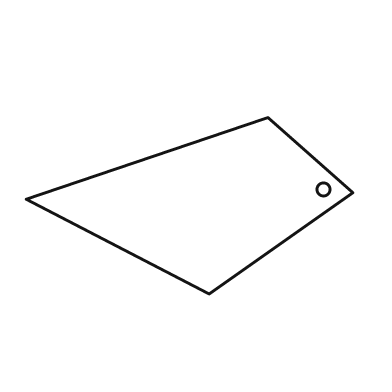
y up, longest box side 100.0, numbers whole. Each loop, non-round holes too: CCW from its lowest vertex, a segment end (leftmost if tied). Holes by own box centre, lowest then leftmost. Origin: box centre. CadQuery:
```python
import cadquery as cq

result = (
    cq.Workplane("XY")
    .moveTo(6.0, -27.0)
    .lineTo(50.0, 4.0)
    .lineTo(24.0, 27.0)
    .lineTo(-50.0, 2.0)
    .close()
    .moveTo(41.0, 5.0)
    .circle(2.0)
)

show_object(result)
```